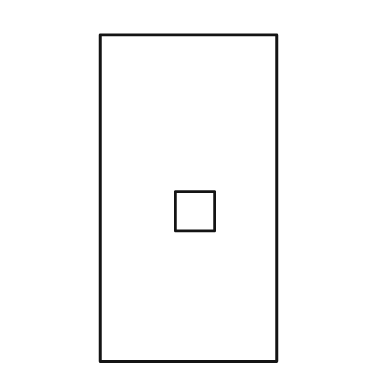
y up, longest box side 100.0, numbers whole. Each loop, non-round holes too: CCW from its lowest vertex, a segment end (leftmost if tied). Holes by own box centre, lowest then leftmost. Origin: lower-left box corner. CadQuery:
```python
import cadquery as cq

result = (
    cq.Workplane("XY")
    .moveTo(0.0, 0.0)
    .lineTo(54.0, 0.0)
    .lineTo(54.0, 100.0)
    .lineTo(0.0, 100.0)
    .close()
    .moveTo(23.0, 40.0)
    .lineTo(35.0, 40.0)
    .lineTo(35.0, 52.0)
    .lineTo(23.0, 52.0)
    .close()
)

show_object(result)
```